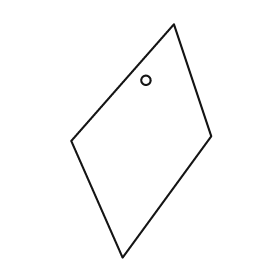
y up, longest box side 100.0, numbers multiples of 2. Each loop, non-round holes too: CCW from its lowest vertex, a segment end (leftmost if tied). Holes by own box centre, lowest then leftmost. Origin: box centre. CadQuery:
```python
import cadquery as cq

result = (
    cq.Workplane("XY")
    .moveTo(-8.0, -50.0)
    .lineTo(30.0, 2.0)
    .lineTo(14.0, 50.0)
    .lineTo(-30.0, 0.0)
    .close()
    .moveTo(2.0, 26.0)
    .circle(2.0)
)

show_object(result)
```